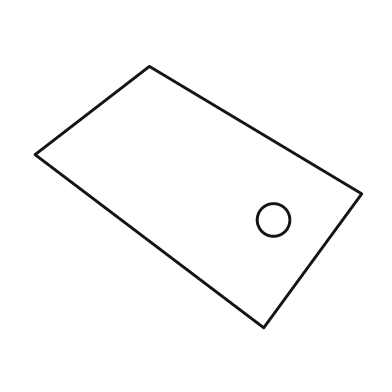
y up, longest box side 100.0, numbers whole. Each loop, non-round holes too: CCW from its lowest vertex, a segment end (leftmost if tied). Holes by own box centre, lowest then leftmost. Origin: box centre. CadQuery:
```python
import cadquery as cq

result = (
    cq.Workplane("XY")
    .moveTo(20.0, -40.0)
    .lineTo(50.0, 1.0)
    .lineTo(-15.0, 40.0)
    .lineTo(-50.0, 13.0)
    .close()
    .moveTo(23.0, -7.0)
    .circle(5.0)
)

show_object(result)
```